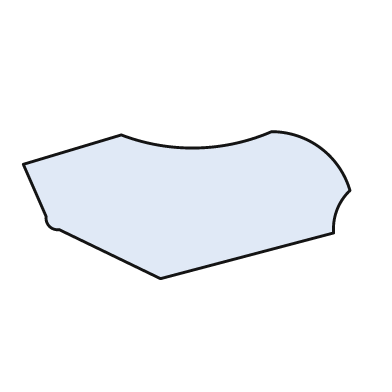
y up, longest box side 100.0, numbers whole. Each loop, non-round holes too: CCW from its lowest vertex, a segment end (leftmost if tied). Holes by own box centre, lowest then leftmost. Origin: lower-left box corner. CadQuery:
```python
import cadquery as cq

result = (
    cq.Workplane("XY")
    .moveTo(42.0, 0.0)
    .lineTo(95.0, 14.0)
    .threePointArc((96.0, 21.0), (100.0, 27.0))
    .threePointArc((91.0, 40.0), (76.0, 45.0))
    .threePointArc((53.0, 40.0), (30.0, 44.0))
    .lineTo(0.0, 35.0)
    .lineTo(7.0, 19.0)
    .threePointArc((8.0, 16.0), (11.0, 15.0))
    .close()
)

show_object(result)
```